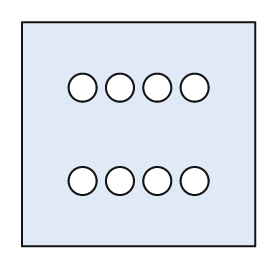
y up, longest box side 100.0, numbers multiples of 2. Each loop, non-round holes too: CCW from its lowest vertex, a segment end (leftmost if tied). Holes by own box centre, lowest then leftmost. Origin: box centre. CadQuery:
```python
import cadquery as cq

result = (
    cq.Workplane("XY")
    .moveTo(-50.0, -48.0)
    .lineTo(50.0, -48.0)
    .lineTo(50.0, 48.0)
    .lineTo(-50.0, 48.0)
    .close()
    .moveTo(-24.0, -20.0)
    .circle(6.0)
    .moveTo(-8.0, -20.0)
    .circle(6.0)
    .moveTo(8.0, -20.0)
    .circle(6.0)
    .moveTo(24.0, -20.0)
    .circle(6.0)
    .moveTo(-24.0, 20.0)
    .circle(6.0)
    .moveTo(-8.0, 20.0)
    .circle(6.0)
    .moveTo(8.0, 20.0)
    .circle(6.0)
    .moveTo(24.0, 20.0)
    .circle(6.0)
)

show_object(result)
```